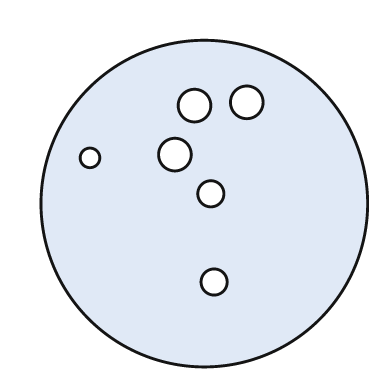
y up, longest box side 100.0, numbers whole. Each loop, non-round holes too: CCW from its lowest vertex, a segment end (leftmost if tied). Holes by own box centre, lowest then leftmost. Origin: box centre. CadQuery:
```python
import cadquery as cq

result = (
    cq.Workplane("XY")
    .moveTo(0.0, 0.0)
    .circle(50.0)
    .moveTo(3.0, -24.0)
    .circle(4.0)
    .moveTo(2.0, 3.0)
    .circle(4.0)
    .moveTo(-35.0, 14.0)
    .circle(3.0)
    .moveTo(-9.0, 15.0)
    .circle(5.0)
    .moveTo(-3.0, 30.0)
    .circle(5.0)
    .moveTo(13.0, 31.0)
    .circle(5.0)
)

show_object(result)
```